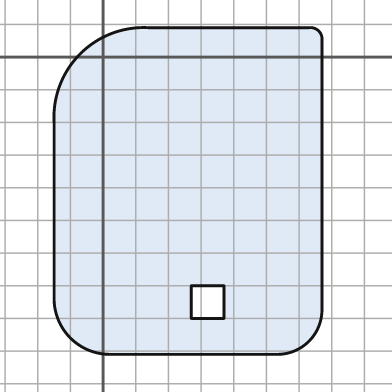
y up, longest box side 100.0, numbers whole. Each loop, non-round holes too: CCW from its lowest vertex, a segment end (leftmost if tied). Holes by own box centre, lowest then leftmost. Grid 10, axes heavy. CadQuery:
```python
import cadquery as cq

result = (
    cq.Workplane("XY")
    .moveTo(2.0, -91.0)
    .lineTo(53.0, -91.0)
    .threePointArc((63.0, -87.0), (67.0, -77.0))
    .lineTo(67.0, 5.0)
    .threePointArc((66.0, 8.0), (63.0, 9.0))
    .lineTo(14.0, 9.0)
    .threePointArc((-7.0, 1.0), (-15.0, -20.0))
    .lineTo(-15.0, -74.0)
    .threePointArc((-10.0, -86.0), (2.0, -91.0))
    .close()
    .moveTo(27.0, -80.0)
    .lineTo(37.0, -80.0)
    .lineTo(37.0, -70.0)
    .lineTo(27.0, -70.0)
    .close()
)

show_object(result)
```